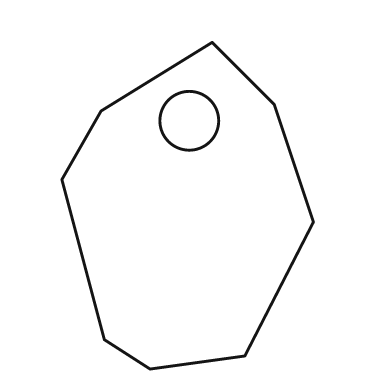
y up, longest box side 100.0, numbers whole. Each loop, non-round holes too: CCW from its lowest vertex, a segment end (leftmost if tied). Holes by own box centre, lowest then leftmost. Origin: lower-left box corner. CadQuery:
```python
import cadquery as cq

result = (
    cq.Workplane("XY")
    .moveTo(27.0, 0.0)
    .lineTo(56.0, 4.0)
    .lineTo(77.0, 45.0)
    .lineTo(65.0, 81.0)
    .lineTo(46.0, 100.0)
    .lineTo(12.0, 79.0)
    .lineTo(0.0, 58.0)
    .lineTo(13.0, 9.0)
    .close()
    .moveTo(39.0, 76.0)
    .circle(9.0)
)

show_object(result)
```